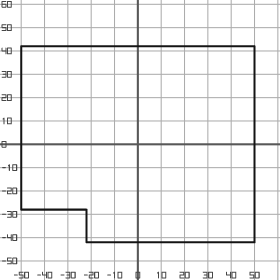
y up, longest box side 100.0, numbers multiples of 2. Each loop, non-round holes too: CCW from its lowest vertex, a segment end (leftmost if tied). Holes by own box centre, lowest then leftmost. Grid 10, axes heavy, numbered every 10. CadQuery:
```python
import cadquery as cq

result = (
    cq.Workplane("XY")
    .moveTo(-22.0, -42.0)
    .lineTo(50.0, -42.0)
    .lineTo(50.0, 42.0)
    .lineTo(-50.0, 42.0)
    .lineTo(-50.0, -28.0)
    .lineTo(-22.0, -28.0)
    .close()
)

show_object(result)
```